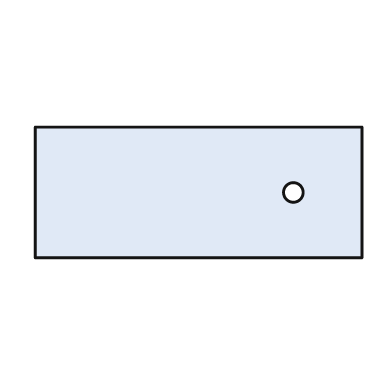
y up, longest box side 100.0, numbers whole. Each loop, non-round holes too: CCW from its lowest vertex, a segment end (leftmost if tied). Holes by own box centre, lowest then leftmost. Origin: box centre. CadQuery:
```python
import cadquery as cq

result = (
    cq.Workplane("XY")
    .moveTo(-50.0, -20.0)
    .lineTo(50.0, -20.0)
    .lineTo(50.0, 20.0)
    .lineTo(-50.0, 20.0)
    .close()
    .moveTo(29.0, 0.0)
    .circle(3.0)
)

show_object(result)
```